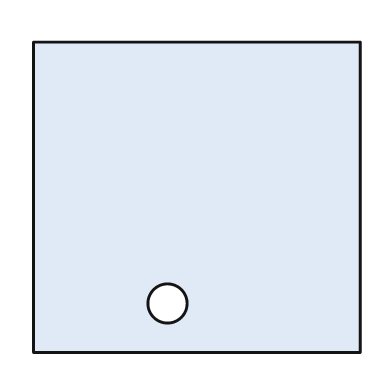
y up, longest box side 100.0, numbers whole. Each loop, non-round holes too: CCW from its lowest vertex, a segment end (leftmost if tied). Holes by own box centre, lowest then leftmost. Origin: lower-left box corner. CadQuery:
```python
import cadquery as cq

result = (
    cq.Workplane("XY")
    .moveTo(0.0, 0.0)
    .lineTo(100.0, 0.0)
    .lineTo(100.0, 95.0)
    .lineTo(0.0, 95.0)
    .close()
    .moveTo(41.0, 15.0)
    .circle(6.0)
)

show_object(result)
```